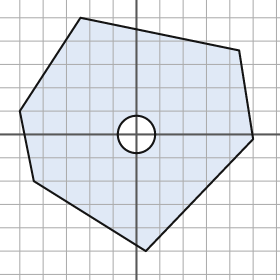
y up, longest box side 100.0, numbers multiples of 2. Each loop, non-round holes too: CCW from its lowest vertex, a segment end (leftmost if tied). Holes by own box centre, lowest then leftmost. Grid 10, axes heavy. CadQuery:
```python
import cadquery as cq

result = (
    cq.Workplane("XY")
    .moveTo(4.0, -50.0)
    .lineTo(50.0, -2.0)
    .lineTo(44.0, 36.0)
    .lineTo(-24.0, 50.0)
    .lineTo(-50.0, 10.0)
    .lineTo(-44.0, -20.0)
    .close()
    .moveTo(0.0, 0.0)
    .circle(8.0)
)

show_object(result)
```